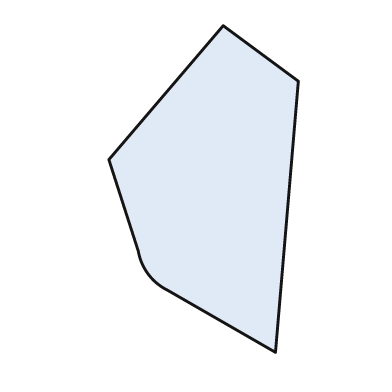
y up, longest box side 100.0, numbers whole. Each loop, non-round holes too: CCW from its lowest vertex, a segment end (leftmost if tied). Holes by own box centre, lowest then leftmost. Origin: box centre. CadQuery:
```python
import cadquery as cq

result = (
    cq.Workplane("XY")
    .moveTo(22.0, -50.0)
    .lineTo(29.0, 33.0)
    .lineTo(6.0, 50.0)
    .lineTo(-29.0, 9.0)
    .lineTo(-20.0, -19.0)
    .threePointArc((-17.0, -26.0), (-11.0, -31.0))
    .close()
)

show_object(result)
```